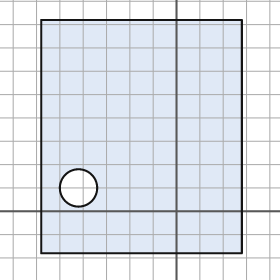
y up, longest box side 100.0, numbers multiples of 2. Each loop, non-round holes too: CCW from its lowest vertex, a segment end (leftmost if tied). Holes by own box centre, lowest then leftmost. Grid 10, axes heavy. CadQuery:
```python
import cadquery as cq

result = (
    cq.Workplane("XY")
    .moveTo(-58.0, -18.0)
    .lineTo(28.0, -18.0)
    .lineTo(28.0, 82.0)
    .lineTo(-58.0, 82.0)
    .close()
    .moveTo(-42.0, 10.0)
    .circle(8.0)
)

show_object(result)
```